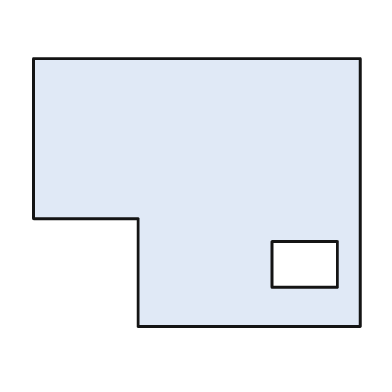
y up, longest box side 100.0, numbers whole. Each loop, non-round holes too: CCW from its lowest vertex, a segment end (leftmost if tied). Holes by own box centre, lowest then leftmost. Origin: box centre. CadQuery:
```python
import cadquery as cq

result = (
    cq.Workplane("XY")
    .moveTo(-18.0, -41.0)
    .lineTo(50.0, -41.0)
    .lineTo(50.0, 41.0)
    .lineTo(-50.0, 41.0)
    .lineTo(-50.0, -8.0)
    .lineTo(-18.0, -8.0)
    .close()
    .moveTo(23.0, -29.0)
    .lineTo(43.0, -29.0)
    .lineTo(43.0, -15.0)
    .lineTo(23.0, -15.0)
    .close()
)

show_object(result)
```